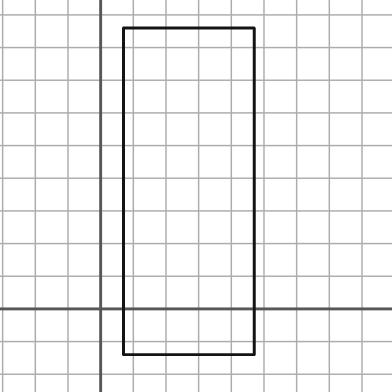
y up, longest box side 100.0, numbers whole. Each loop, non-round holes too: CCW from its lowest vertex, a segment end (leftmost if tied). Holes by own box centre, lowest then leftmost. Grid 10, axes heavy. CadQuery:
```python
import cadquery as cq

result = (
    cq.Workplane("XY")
    .moveTo(7.0, -14.0)
    .lineTo(47.0, -14.0)
    .lineTo(47.0, 86.0)
    .lineTo(7.0, 86.0)
    .close()
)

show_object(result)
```